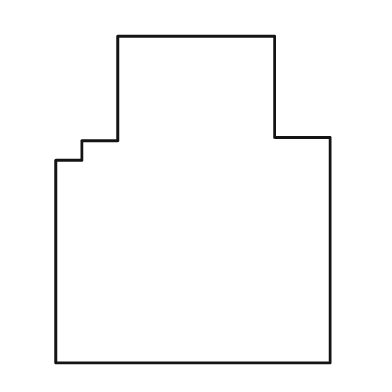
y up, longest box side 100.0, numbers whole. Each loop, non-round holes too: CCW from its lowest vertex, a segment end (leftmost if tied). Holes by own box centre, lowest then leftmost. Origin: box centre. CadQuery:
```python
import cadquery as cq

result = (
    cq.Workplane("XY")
    .moveTo(-42.0, -50.0)
    .lineTo(42.0, -50.0)
    .lineTo(42.0, 19.0)
    .lineTo(25.0, 19.0)
    .lineTo(25.0, 50.0)
    .lineTo(-23.0, 50.0)
    .lineTo(-23.0, 18.0)
    .lineTo(-34.0, 18.0)
    .lineTo(-34.0, 12.0)
    .lineTo(-42.0, 12.0)
    .close()
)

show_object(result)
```